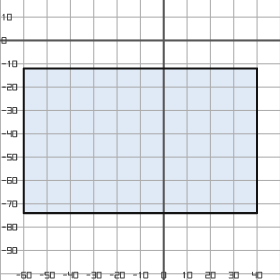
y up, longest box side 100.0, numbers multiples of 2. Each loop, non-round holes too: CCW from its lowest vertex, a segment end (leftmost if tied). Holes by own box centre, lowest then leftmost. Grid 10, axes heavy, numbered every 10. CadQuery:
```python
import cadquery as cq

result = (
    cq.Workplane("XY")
    .moveTo(-60.0, -74.0)
    .lineTo(40.0, -74.0)
    .lineTo(40.0, -12.0)
    .lineTo(-60.0, -12.0)
    .close()
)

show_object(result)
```